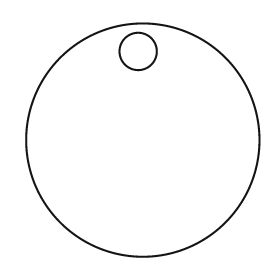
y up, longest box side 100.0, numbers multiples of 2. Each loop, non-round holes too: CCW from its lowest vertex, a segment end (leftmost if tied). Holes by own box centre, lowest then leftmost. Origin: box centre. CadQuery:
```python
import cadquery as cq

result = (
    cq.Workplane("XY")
    .moveTo(0.0, 0.0)
    .circle(50.0)
    .moveTo(-2.0, 38.0)
    .circle(8.0)
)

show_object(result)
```